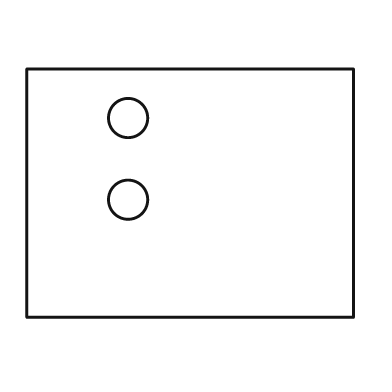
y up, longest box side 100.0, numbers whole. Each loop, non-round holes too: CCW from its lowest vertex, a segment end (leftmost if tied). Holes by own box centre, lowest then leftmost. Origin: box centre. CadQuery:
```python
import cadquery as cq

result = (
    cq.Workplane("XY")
    .moveTo(-50.0, -38.0)
    .lineTo(50.0, -38.0)
    .lineTo(50.0, 38.0)
    .lineTo(-50.0, 38.0)
    .close()
    .moveTo(-19.0, -2.0)
    .circle(6.0)
    .moveTo(-19.0, 23.0)
    .circle(6.0)
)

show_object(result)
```